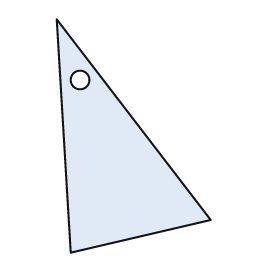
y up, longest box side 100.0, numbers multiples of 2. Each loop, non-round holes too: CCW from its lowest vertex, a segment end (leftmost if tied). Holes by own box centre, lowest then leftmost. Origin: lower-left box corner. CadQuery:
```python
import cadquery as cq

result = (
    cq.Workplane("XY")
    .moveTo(6.0, 0.0)
    .lineTo(66.0, 14.0)
    .lineTo(0.0, 100.0)
    .close()
    .moveTo(10.0, 74.0)
    .circle(4.0)
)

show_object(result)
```